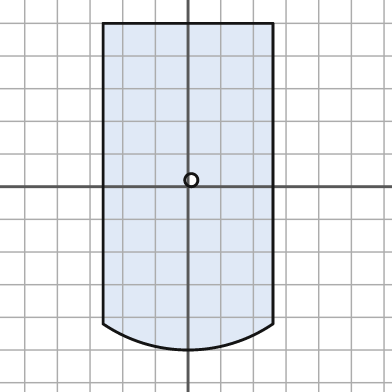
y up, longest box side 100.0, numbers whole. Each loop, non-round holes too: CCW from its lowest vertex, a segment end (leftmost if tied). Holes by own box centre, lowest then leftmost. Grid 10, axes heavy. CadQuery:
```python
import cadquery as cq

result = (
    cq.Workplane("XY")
    .moveTo(-26.0, -42.0)
    .threePointArc((0.0, -50.0), (26.0, -42.0))
    .lineTo(26.0, 50.0)
    .lineTo(-26.0, 50.0)
    .close()
    .moveTo(1.0, 2.0)
    .circle(2.0)
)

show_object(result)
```